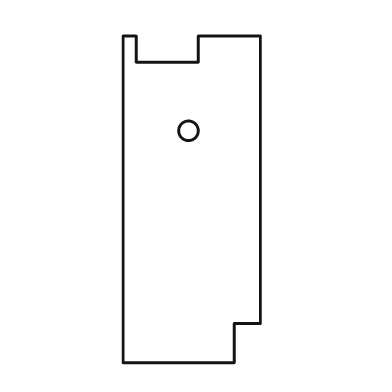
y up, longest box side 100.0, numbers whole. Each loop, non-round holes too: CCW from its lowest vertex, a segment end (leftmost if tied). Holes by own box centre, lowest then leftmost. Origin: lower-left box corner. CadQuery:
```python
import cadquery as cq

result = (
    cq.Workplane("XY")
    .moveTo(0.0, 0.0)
    .lineTo(34.0, 0.0)
    .lineTo(34.0, 12.0)
    .lineTo(42.0, 12.0)
    .lineTo(42.0, 100.0)
    .lineTo(23.0, 100.0)
    .lineTo(23.0, 92.0)
    .lineTo(4.0, 92.0)
    .lineTo(4.0, 100.0)
    .lineTo(0.0, 100.0)
    .close()
    .moveTo(20.0, 71.0)
    .circle(3.0)
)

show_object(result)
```